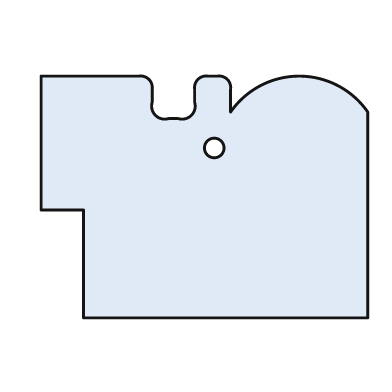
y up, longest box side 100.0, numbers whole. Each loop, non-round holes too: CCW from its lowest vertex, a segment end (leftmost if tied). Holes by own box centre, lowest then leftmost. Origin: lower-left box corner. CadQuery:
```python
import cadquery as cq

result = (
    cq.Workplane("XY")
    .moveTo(13.0, 0.0)
    .lineTo(100.0, 0.0)
    .lineTo(100.0, 63.0)
    .threePointArc((79.0, 74.0), (58.0, 63.0))
    .lineTo(58.0, 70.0)
    .threePointArc((57.0, 73.0), (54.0, 74.0))
    .lineTo(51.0, 74.0)
    .threePointArc((48.0, 73.0), (47.0, 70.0))
    .lineTo(47.0, 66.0)
    .threePointArc((46.0, 62.0), (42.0, 61.0))
    .lineTo(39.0, 61.0)
    .threePointArc((35.0, 62.0), (34.0, 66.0))
    .lineTo(34.0, 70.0)
    .threePointArc((33.0, 73.0), (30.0, 74.0))
    .lineTo(0.0, 74.0)
    .lineTo(0.0, 33.0)
    .lineTo(13.0, 33.0)
    .close()
    .moveTo(53.0, 52.0)
    .circle(3.0)
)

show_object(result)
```